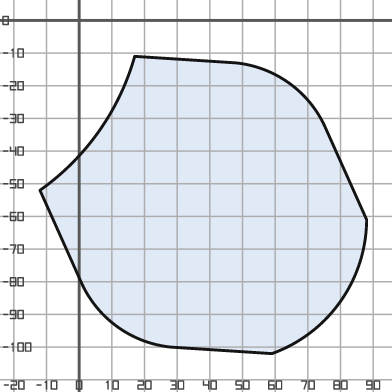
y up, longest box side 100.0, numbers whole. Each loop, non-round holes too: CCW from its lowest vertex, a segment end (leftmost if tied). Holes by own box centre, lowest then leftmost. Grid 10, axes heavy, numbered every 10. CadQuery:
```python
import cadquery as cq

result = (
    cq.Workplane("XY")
    .moveTo(59.0, -102.0)
    .threePointArc((80.0, -86.0), (88.0, -61.0))
    .lineTo(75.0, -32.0)
    .threePointArc((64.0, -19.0), (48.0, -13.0))
    .lineTo(17.0, -11.0)
    .threePointArc((6.0, -34.0), (-12.0, -52.0))
    .lineTo(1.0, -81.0)
    .threePointArc((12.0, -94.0), (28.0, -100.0))
    .close()
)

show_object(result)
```